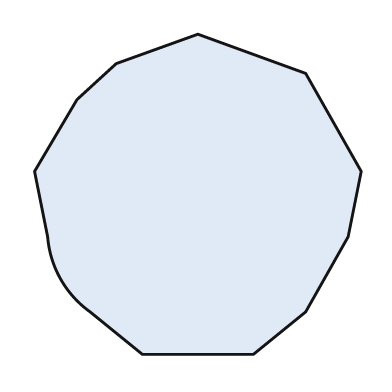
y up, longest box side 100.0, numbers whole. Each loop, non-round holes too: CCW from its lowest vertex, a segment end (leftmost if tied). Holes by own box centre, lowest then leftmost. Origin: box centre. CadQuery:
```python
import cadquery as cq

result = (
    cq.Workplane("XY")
    .moveTo(-17.0, -49.0)
    .lineTo(17.0, -49.0)
    .lineTo(33.0, -36.0)
    .lineTo(46.0, -13.0)
    .lineTo(50.0, 7.0)
    .lineTo(33.0, 37.0)
    .lineTo(0.0, 49.0)
    .lineTo(-25.0, 40.0)
    .lineTo(-37.0, 29.0)
    .lineTo(-50.0, 7.0)
    .lineTo(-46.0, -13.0)
    .threePointArc((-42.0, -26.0), (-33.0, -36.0))
    .close()
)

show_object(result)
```